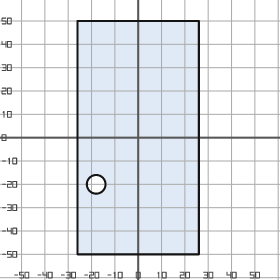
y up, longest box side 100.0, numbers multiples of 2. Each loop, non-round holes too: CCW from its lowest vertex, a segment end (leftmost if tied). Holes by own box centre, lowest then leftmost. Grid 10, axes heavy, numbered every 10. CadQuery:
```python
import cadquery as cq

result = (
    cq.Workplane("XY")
    .moveTo(-26.0, -50.0)
    .lineTo(26.0, -50.0)
    .lineTo(26.0, 50.0)
    .lineTo(-26.0, 50.0)
    .close()
    .moveTo(-18.0, -20.0)
    .circle(4.0)
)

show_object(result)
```